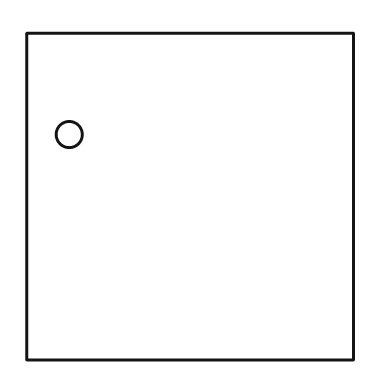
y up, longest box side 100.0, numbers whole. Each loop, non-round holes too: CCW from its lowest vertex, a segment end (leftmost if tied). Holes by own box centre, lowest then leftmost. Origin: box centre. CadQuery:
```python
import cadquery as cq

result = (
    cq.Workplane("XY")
    .moveTo(-50.0, -50.0)
    .lineTo(50.0, -50.0)
    .lineTo(50.0, 50.0)
    .lineTo(-50.0, 50.0)
    .close()
    .moveTo(-37.0, 19.0)
    .circle(4.0)
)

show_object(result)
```